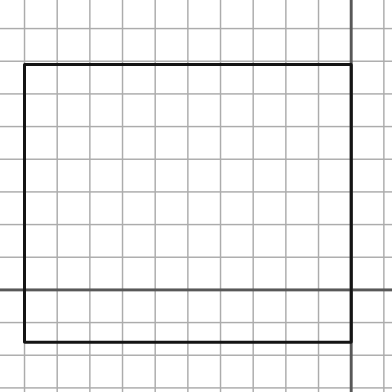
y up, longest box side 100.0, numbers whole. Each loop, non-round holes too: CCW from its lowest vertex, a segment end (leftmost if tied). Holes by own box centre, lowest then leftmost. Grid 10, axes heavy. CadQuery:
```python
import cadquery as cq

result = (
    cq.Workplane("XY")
    .moveTo(-100.0, -16.0)
    .lineTo(0.0, -16.0)
    .lineTo(0.0, 69.0)
    .lineTo(-100.0, 69.0)
    .close()
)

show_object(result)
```